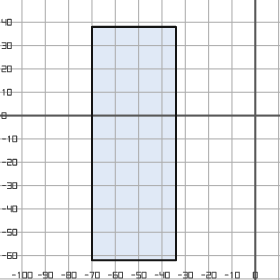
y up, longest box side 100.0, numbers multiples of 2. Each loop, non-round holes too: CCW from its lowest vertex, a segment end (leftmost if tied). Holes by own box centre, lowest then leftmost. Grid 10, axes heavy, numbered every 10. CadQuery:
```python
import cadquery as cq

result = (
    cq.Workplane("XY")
    .moveTo(-70.0, -62.0)
    .lineTo(-34.0, -62.0)
    .lineTo(-34.0, 38.0)
    .lineTo(-70.0, 38.0)
    .close()
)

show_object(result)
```